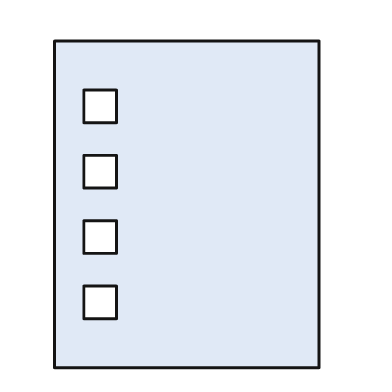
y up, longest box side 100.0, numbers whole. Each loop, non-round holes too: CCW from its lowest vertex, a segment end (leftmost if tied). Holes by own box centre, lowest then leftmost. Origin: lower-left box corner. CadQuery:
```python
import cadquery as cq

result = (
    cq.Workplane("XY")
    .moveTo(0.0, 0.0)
    .lineTo(81.0, 0.0)
    .lineTo(81.0, 100.0)
    .lineTo(0.0, 100.0)
    .close()
    .moveTo(9.0, 15.0)
    .lineTo(19.0, 15.0)
    .lineTo(19.0, 25.0)
    .lineTo(9.0, 25.0)
    .close()
    .moveTo(9.0, 35.0)
    .lineTo(19.0, 35.0)
    .lineTo(19.0, 45.0)
    .lineTo(9.0, 45.0)
    .close()
    .moveTo(9.0, 55.0)
    .lineTo(19.0, 55.0)
    .lineTo(19.0, 65.0)
    .lineTo(9.0, 65.0)
    .close()
    .moveTo(9.0, 75.0)
    .lineTo(19.0, 75.0)
    .lineTo(19.0, 85.0)
    .lineTo(9.0, 85.0)
    .close()
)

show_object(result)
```